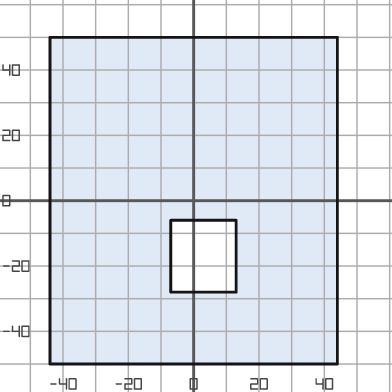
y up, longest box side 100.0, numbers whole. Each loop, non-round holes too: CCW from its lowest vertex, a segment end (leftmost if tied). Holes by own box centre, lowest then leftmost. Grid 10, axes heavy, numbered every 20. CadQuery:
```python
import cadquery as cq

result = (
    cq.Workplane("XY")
    .moveTo(-44.0, -50.0)
    .lineTo(44.0, -50.0)
    .lineTo(44.0, 50.0)
    .lineTo(-44.0, 50.0)
    .close()
    .moveTo(-7.0, -28.0)
    .lineTo(13.0, -28.0)
    .lineTo(13.0, -6.0)
    .lineTo(-7.0, -6.0)
    .close()
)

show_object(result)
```